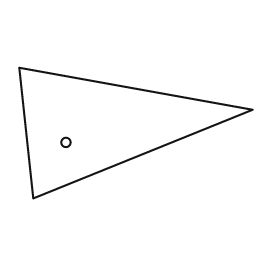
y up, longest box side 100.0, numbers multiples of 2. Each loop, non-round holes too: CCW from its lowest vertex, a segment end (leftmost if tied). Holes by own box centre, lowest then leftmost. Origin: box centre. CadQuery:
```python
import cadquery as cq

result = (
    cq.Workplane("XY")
    .moveTo(-44.0, -28.0)
    .lineTo(50.0, 10.0)
    .lineTo(-50.0, 28.0)
    .close()
    .moveTo(-30.0, -4.0)
    .circle(2.0)
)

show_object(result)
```